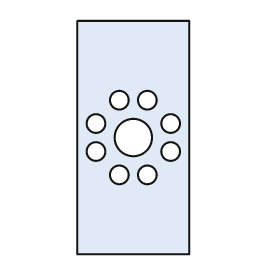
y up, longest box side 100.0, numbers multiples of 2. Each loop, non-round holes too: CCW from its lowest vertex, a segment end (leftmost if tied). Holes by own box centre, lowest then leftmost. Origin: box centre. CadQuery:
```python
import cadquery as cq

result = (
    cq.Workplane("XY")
    .moveTo(-24.0, -50.0)
    .lineTo(24.0, -50.0)
    .lineTo(24.0, 50.0)
    .lineTo(-24.0, 50.0)
    .close()
    .moveTo(-6.0, -16.0)
    .circle(4.0)
    .moveTo(6.0, -16.0)
    .circle(4.0)
    .moveTo(-16.0, -6.0)
    .circle(4.0)
    .moveTo(16.0, -6.0)
    .circle(4.0)
    .moveTo(0.0, 0.0)
    .circle(8.0)
    .moveTo(-16.0, 6.0)
    .circle(4.0)
    .moveTo(16.0, 6.0)
    .circle(4.0)
    .moveTo(-6.0, 16.0)
    .circle(4.0)
    .moveTo(6.0, 16.0)
    .circle(4.0)
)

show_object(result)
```